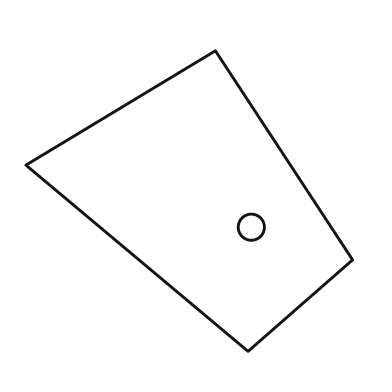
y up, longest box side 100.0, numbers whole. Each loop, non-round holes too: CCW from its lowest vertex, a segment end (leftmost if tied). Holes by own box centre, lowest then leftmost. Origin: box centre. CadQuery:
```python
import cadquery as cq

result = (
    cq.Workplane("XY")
    .moveTo(18.0, -46.0)
    .lineTo(50.0, -18.0)
    .lineTo(8.0, 46.0)
    .lineTo(-50.0, 11.0)
    .close()
    .moveTo(19.0, -8.0)
    .circle(4.0)
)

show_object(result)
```